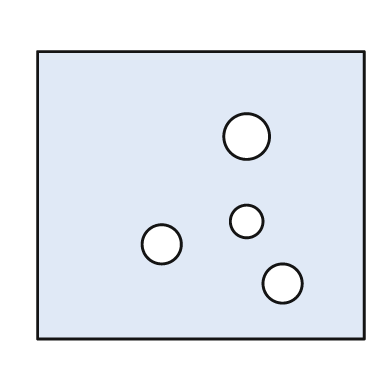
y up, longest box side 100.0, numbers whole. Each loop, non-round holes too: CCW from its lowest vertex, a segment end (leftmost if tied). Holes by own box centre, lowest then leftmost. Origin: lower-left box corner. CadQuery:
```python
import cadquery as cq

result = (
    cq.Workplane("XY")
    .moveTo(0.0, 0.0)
    .lineTo(100.0, 0.0)
    .lineTo(100.0, 88.0)
    .lineTo(0.0, 88.0)
    .close()
    .moveTo(75.0, 17.0)
    .circle(6.0)
    .moveTo(38.0, 29.0)
    .circle(6.0)
    .moveTo(64.0, 36.0)
    .circle(5.0)
    .moveTo(64.0, 62.0)
    .circle(7.0)
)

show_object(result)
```